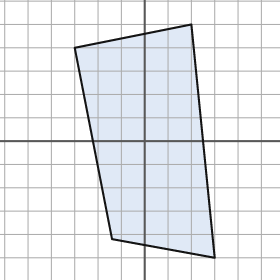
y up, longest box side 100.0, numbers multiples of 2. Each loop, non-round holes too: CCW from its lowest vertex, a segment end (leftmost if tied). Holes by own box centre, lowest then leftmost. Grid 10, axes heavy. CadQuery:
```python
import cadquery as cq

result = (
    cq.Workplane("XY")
    .moveTo(30.0, -50.0)
    .lineTo(20.0, 50.0)
    .lineTo(-30.0, 40.0)
    .lineTo(-14.0, -42.0)
    .close()
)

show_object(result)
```